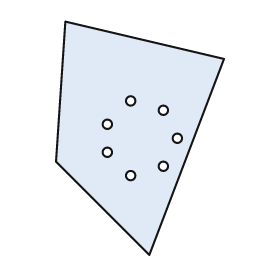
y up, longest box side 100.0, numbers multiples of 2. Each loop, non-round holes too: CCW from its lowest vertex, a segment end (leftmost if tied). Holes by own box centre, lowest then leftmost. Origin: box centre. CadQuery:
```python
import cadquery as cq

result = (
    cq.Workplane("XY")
    .moveTo(4.0, -50.0)
    .lineTo(36.0, 34.0)
    .lineTo(-32.0, 50.0)
    .lineTo(-36.0, -10.0)
    .close()
    .moveTo(-4.0, -16.0)
    .circle(2.0)
    .moveTo(10.0, -12.0)
    .circle(2.0)
    .moveTo(-14.0, -6.0)
    .circle(2.0)
    .moveTo(16.0, 0.0)
    .circle(2.0)
    .moveTo(-14.0, 6.0)
    .circle(2.0)
    .moveTo(10.0, 12.0)
    .circle(2.0)
    .moveTo(-4.0, 16.0)
    .circle(2.0)
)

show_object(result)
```